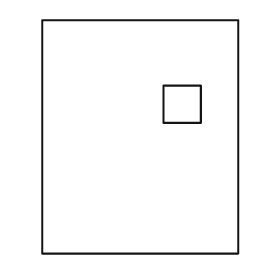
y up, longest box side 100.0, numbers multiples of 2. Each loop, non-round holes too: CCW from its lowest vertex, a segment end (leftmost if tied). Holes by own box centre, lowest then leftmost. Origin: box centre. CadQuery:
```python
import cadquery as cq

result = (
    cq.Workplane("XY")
    .moveTo(-42.0, -50.0)
    .lineTo(42.0, -50.0)
    .lineTo(42.0, 50.0)
    .lineTo(-42.0, 50.0)
    .close()
    .moveTo(10.0, 6.0)
    .lineTo(26.0, 6.0)
    .lineTo(26.0, 22.0)
    .lineTo(10.0, 22.0)
    .close()
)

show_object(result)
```